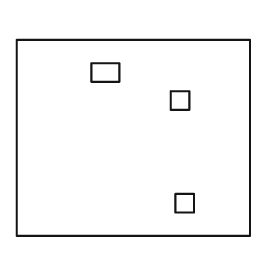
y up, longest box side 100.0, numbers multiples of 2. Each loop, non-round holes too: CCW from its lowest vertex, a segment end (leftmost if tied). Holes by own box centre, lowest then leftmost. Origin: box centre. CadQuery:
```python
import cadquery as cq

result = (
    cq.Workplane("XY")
    .moveTo(-50.0, -42.0)
    .lineTo(50.0, -42.0)
    .lineTo(50.0, 42.0)
    .lineTo(-50.0, 42.0)
    .close()
    .moveTo(18.0, -32.0)
    .lineTo(26.0, -32.0)
    .lineTo(26.0, -24.0)
    .lineTo(18.0, -24.0)
    .close()
    .moveTo(16.0, 12.0)
    .lineTo(24.0, 12.0)
    .lineTo(24.0, 20.0)
    .lineTo(16.0, 20.0)
    .close()
    .moveTo(-18.0, 24.0)
    .lineTo(-6.0, 24.0)
    .lineTo(-6.0, 32.0)
    .lineTo(-18.0, 32.0)
    .close()
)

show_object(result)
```